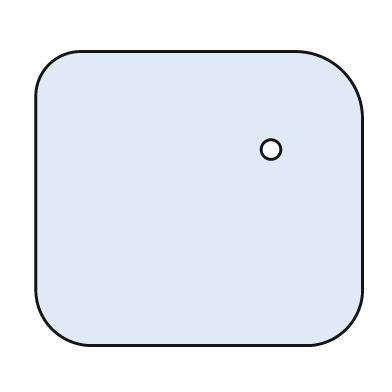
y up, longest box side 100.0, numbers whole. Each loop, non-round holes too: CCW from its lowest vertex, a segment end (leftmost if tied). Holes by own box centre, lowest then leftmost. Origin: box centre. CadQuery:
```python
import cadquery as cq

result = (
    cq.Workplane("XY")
    .moveTo(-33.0, -45.0)
    .lineTo(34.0, -45.0)
    .threePointArc((45.0, -40.0), (50.0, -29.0))
    .lineTo(50.0, 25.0)
    .threePointArc((44.0, 39.0), (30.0, 45.0))
    .lineTo(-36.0, 45.0)
    .threePointArc((-46.0, 41.0), (-50.0, 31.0))
    .lineTo(-50.0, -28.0)
    .threePointArc((-45.0, -40.0), (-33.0, -45.0))
    .close()
    .moveTo(22.0, 15.0)
    .circle(3.0)
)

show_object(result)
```